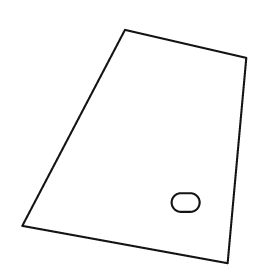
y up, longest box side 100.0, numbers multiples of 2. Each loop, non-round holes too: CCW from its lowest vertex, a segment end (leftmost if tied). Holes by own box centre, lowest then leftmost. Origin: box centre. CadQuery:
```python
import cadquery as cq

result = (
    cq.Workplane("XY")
    .moveTo(40.0, -50.0)
    .lineTo(48.0, 38.0)
    .lineTo(-4.0, 50.0)
    .lineTo(-48.0, -34.0)
    .close()
    .moveTo(20.0, -28.0)
    .lineTo(24.0, -28.0)
    .threePointArc((28.0, -24.0), (24.0, -20.0))
    .lineTo(20.0, -20.0)
    .threePointArc((16.0, -24.0), (20.0, -28.0))
    .close()
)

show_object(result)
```